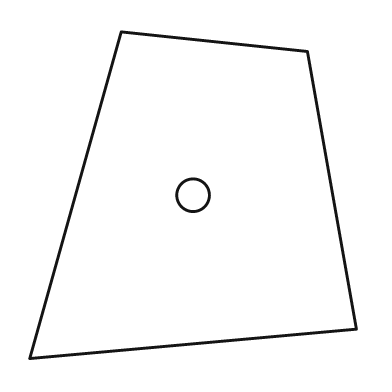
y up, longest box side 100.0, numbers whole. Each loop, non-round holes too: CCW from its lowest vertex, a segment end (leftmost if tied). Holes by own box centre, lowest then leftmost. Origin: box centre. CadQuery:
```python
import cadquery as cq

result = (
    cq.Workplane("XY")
    .moveTo(-50.0, -50.0)
    .lineTo(50.0, -41.0)
    .lineTo(35.0, 44.0)
    .lineTo(-22.0, 50.0)
    .close()
    .moveTo(0.0, 0.0)
    .circle(5.0)
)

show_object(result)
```